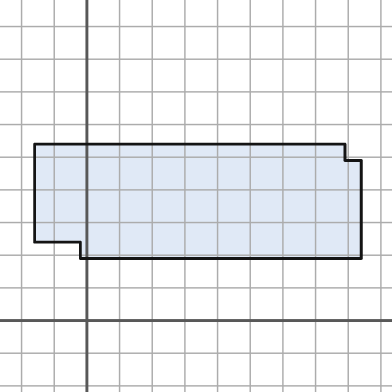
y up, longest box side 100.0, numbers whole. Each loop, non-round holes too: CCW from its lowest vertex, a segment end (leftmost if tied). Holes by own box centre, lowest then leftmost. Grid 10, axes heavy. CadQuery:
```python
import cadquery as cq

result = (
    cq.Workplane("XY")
    .moveTo(-2.0, 19.0)
    .lineTo(84.0, 19.0)
    .lineTo(84.0, 49.0)
    .lineTo(79.0, 49.0)
    .lineTo(79.0, 54.0)
    .lineTo(-16.0, 54.0)
    .lineTo(-16.0, 24.0)
    .lineTo(-2.0, 24.0)
    .close()
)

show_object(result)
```